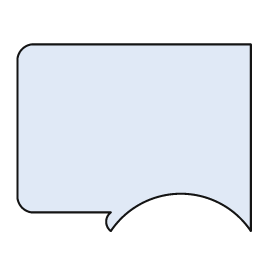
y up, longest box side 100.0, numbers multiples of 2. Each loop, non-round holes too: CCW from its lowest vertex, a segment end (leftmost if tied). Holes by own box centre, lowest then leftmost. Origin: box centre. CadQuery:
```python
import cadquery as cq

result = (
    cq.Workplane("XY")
    .moveTo(-10.0, -40.0)
    .threePointArc((20.0, -24.0), (50.0, -40.0))
    .lineTo(50.0, 40.0)
    .lineTo(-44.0, 40.0)
    .threePointArc((-48.0, 38.0), (-50.0, 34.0))
    .lineTo(-50.0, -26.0)
    .threePointArc((-48.0, -30.0), (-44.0, -32.0))
    .lineTo(-10.0, -32.0)
    .threePointArc((-12.0, -36.0), (-10.0, -40.0))
    .close()
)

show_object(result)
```